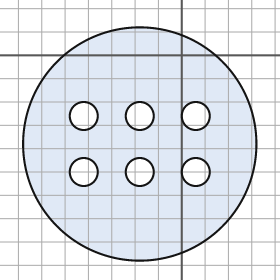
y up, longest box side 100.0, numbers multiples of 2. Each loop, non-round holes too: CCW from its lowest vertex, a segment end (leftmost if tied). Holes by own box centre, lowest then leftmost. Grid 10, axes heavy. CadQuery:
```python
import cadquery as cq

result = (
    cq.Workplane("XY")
    .moveTo(-18.0, -38.0)
    .circle(50.0)
    .moveTo(-42.0, -50.0)
    .circle(6.0)
    .moveTo(-18.0, -50.0)
    .circle(6.0)
    .moveTo(6.0, -50.0)
    .circle(6.0)
    .moveTo(-42.0, -26.0)
    .circle(6.0)
    .moveTo(-18.0, -26.0)
    .circle(6.0)
    .moveTo(6.0, -26.0)
    .circle(6.0)
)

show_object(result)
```